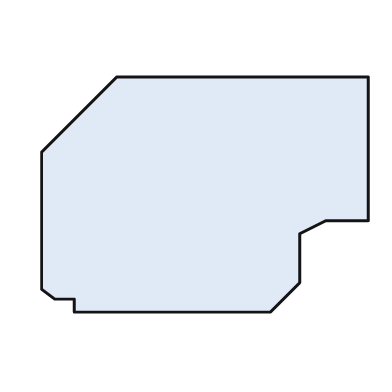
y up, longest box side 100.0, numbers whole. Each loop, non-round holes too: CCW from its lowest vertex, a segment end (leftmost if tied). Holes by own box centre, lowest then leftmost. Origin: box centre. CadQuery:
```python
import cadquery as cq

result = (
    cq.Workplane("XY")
    .moveTo(-40.0, -36.0)
    .lineTo(20.0, -36.0)
    .lineTo(29.0, -27.0)
    .lineTo(29.0, -12.0)
    .lineTo(37.0, -8.0)
    .lineTo(50.0, -8.0)
    .lineTo(50.0, 36.0)
    .lineTo(-27.0, 36.0)
    .lineTo(-50.0, 13.0)
    .lineTo(-50.0, -29.0)
    .lineTo(-46.0, -32.0)
    .lineTo(-40.0, -32.0)
    .close()
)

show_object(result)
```